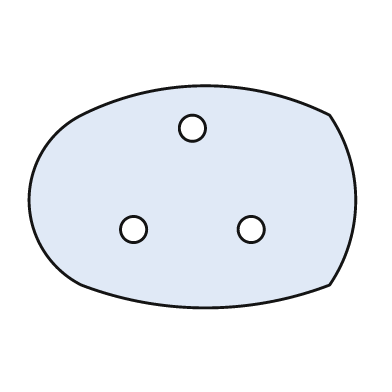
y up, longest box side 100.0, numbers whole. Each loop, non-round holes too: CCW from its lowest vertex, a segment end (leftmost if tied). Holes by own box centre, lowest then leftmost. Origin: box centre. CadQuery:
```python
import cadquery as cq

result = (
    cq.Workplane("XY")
    .moveTo(-34.0, -27.0)
    .threePointArc((4.0, -34.0), (42.0, -27.0))
    .threePointArc((50.0, -1.0), (42.0, 25.0))
    .threePointArc((4.0, 34.0), (-34.0, 25.0))
    .threePointArc((-50.0, -1.0), (-34.0, -27.0))
    .close()
    .moveTo(-18.0, -10.0)
    .circle(4.0)
    .moveTo(18.0, -10.0)
    .circle(4.0)
    .moveTo(0.0, 21.0)
    .circle(4.0)
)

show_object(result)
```